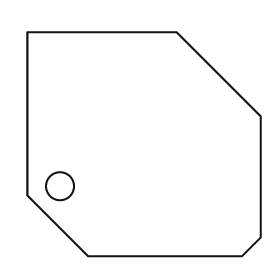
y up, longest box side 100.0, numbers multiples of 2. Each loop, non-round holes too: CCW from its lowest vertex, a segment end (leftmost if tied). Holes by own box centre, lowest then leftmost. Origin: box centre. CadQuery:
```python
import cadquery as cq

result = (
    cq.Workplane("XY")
    .moveTo(-24.0, -48.0)
    .lineTo(42.0, -48.0)
    .lineTo(50.0, -40.0)
    .lineTo(50.0, 12.0)
    .lineTo(14.0, 48.0)
    .lineTo(-50.0, 48.0)
    .lineTo(-50.0, -22.0)
    .close()
    .moveTo(-36.0, -18.0)
    .circle(6.0)
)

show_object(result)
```